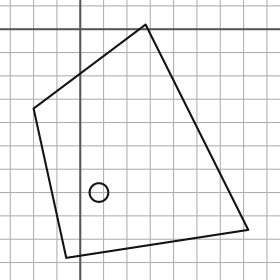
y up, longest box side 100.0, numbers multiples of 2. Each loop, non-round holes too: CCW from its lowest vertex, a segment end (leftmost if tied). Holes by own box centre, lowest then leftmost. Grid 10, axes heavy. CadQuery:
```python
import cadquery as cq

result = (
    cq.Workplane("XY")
    .moveTo(-6.0, -98.0)
    .lineTo(72.0, -86.0)
    .lineTo(28.0, 2.0)
    .lineTo(-20.0, -34.0)
    .close()
    .moveTo(8.0, -70.0)
    .circle(4.0)
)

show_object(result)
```